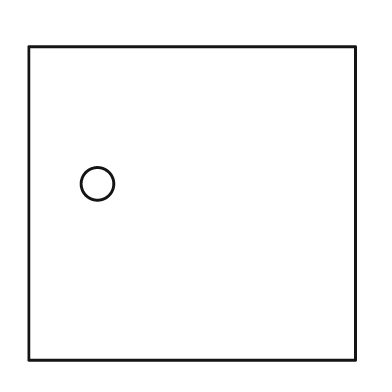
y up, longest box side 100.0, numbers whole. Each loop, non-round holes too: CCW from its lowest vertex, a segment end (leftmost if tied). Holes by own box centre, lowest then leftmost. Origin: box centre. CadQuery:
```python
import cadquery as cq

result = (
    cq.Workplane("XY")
    .moveTo(-50.0, -48.0)
    .lineTo(50.0, -48.0)
    .lineTo(50.0, 48.0)
    .lineTo(-50.0, 48.0)
    .close()
    .moveTo(-29.0, 6.0)
    .circle(5.0)
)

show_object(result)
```